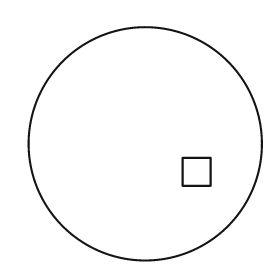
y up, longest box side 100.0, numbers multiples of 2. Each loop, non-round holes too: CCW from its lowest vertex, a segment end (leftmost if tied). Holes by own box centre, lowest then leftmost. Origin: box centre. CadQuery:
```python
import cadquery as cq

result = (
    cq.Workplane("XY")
    .moveTo(0.0, 0.0)
    .circle(50.0)
    .moveTo(16.0, -18.0)
    .lineTo(28.0, -18.0)
    .lineTo(28.0, -6.0)
    .lineTo(16.0, -6.0)
    .close()
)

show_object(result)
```